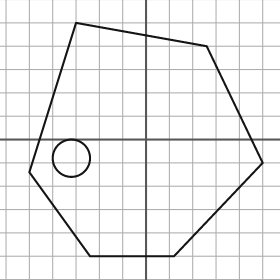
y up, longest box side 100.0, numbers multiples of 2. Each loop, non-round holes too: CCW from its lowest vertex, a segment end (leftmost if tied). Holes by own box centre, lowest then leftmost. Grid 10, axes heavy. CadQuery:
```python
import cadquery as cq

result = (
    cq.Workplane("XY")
    .moveTo(-24.0, -50.0)
    .lineTo(12.0, -50.0)
    .lineTo(50.0, -10.0)
    .lineTo(26.0, 40.0)
    .lineTo(-30.0, 50.0)
    .lineTo(-50.0, -14.0)
    .close()
    .moveTo(-32.0, -8.0)
    .circle(8.0)
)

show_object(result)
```